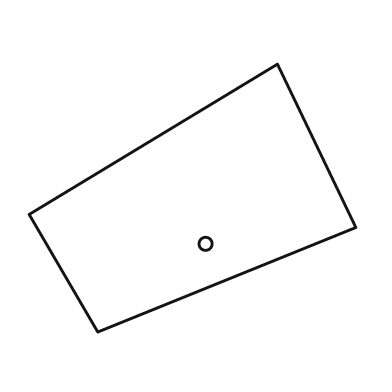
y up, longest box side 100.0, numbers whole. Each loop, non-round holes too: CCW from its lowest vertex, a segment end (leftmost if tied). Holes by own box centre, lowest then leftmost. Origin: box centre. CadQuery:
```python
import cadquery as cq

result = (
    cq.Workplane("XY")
    .moveTo(-29.0, -41.0)
    .lineTo(50.0, -9.0)
    .lineTo(26.0, 41.0)
    .lineTo(-50.0, -5.0)
    .close()
    .moveTo(4.0, -14.0)
    .circle(2.0)
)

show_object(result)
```